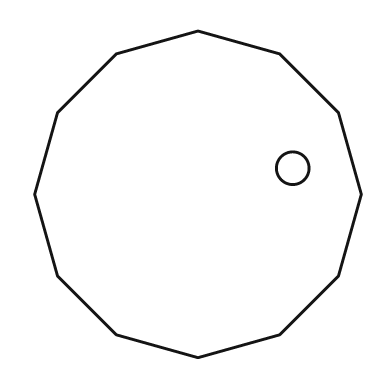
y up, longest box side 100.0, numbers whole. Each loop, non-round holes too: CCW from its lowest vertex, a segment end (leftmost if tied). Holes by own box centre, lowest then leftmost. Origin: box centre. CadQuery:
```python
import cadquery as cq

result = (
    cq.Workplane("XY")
    .moveTo(0.0, -50.0)
    .lineTo(25.0, -43.0)
    .lineTo(43.0, -25.0)
    .lineTo(50.0, 0.0)
    .lineTo(43.0, 25.0)
    .lineTo(25.0, 43.0)
    .lineTo(0.0, 50.0)
    .lineTo(-25.0, 43.0)
    .lineTo(-43.0, 25.0)
    .lineTo(-50.0, 0.0)
    .lineTo(-43.0, -25.0)
    .lineTo(-25.0, -43.0)
    .close()
    .moveTo(29.0, 8.0)
    .circle(5.0)
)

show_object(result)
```